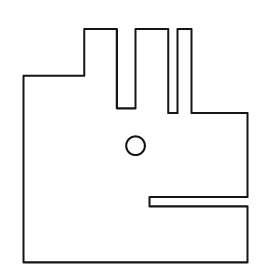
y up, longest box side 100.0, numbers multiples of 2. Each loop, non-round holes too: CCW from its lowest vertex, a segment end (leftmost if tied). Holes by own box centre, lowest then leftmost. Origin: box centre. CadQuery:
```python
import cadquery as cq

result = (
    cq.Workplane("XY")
    .moveTo(-48.0, -50.0)
    .lineTo(48.0, -50.0)
    .lineTo(48.0, -26.0)
    .lineTo(6.0, -26.0)
    .lineTo(6.0, -22.0)
    .lineTo(48.0, -22.0)
    .lineTo(48.0, 14.0)
    .lineTo(24.0, 14.0)
    .lineTo(24.0, 50.0)
    .lineTo(18.0, 50.0)
    .lineTo(18.0, 14.0)
    .lineTo(14.0, 14.0)
    .lineTo(14.0, 50.0)
    .lineTo(0.0, 50.0)
    .lineTo(0.0, 16.0)
    .lineTo(-8.0, 16.0)
    .lineTo(-8.0, 50.0)
    .lineTo(-22.0, 50.0)
    .lineTo(-22.0, 30.0)
    .lineTo(-48.0, 30.0)
    .close()
    .moveTo(0.0, 0.0)
    .circle(4.0)
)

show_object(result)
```